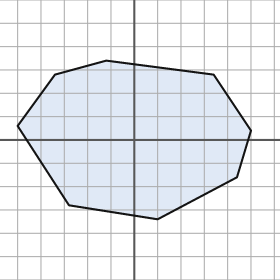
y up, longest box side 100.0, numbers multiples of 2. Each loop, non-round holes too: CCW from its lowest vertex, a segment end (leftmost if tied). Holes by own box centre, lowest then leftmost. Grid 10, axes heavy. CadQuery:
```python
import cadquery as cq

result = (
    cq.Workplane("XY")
    .moveTo(10.0, -34.0)
    .lineTo(44.0, -16.0)
    .lineTo(50.0, 4.0)
    .lineTo(34.0, 28.0)
    .lineTo(-12.0, 34.0)
    .lineTo(-34.0, 28.0)
    .lineTo(-50.0, 6.0)
    .lineTo(-28.0, -28.0)
    .close()
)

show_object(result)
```